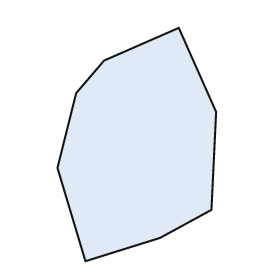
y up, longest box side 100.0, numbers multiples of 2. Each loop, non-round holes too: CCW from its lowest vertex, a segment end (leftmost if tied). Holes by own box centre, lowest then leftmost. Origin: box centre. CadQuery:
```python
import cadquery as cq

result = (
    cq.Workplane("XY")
    .moveTo(-22.0, -50.0)
    .lineTo(10.0, -40.0)
    .lineTo(32.0, -28.0)
    .lineTo(34.0, 14.0)
    .lineTo(18.0, 50.0)
    .lineTo(-14.0, 36.0)
    .lineTo(-26.0, 22.0)
    .lineTo(-34.0, -10.0)
    .close()
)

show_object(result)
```